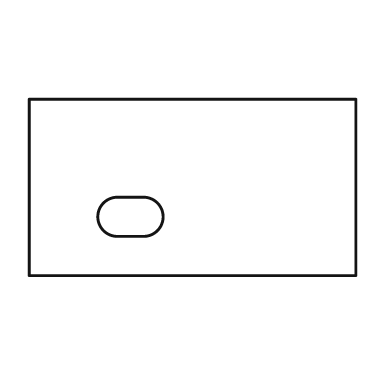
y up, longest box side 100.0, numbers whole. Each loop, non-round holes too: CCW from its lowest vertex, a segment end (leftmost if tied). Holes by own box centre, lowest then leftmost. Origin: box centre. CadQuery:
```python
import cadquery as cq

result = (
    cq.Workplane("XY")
    .moveTo(-50.0, -27.0)
    .lineTo(50.0, -27.0)
    .lineTo(50.0, 27.0)
    .lineTo(-50.0, 27.0)
    .close()
    .moveTo(-23.0, -15.0)
    .lineTo(-15.0, -15.0)
    .threePointArc((-9.0, -9.0), (-15.0, -3.0))
    .lineTo(-23.0, -3.0)
    .threePointArc((-29.0, -9.0), (-23.0, -15.0))
    .close()
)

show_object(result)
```